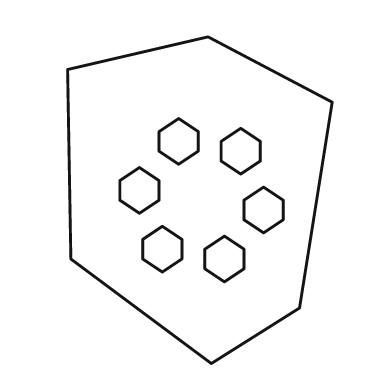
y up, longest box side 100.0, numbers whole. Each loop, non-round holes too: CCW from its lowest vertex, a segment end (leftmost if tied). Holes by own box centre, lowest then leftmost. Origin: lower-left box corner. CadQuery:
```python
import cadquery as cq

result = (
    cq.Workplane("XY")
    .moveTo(44.0, 0.0)
    .lineTo(71.0, 17.0)
    .lineTo(81.0, 80.0)
    .lineTo(43.0, 100.0)
    .lineTo(0.0, 90.0)
    .lineTo(1.0, 32.0)
    .close()
    .moveTo(48.0, 25.0)
    .lineTo(54.0, 29.0)
    .lineTo(54.0, 35.0)
    .lineTo(48.0, 39.0)
    .lineTo(42.0, 35.0)
    .lineTo(42.0, 29.0)
    .close()
    .moveTo(29.0, 28.0)
    .lineTo(35.0, 32.0)
    .lineTo(35.0, 38.0)
    .lineTo(29.0, 42.0)
    .lineTo(23.0, 38.0)
    .lineTo(23.0, 32.0)
    .close()
    .moveTo(60.0, 40.0)
    .lineTo(66.0, 44.0)
    .lineTo(66.0, 50.0)
    .lineTo(60.0, 54.0)
    .lineTo(54.0, 50.0)
    .lineTo(54.0, 44.0)
    .close()
    .moveTo(22.0, 46.0)
    .lineTo(28.0, 50.0)
    .lineTo(28.0, 56.0)
    .lineTo(22.0, 60.0)
    .lineTo(16.0, 56.0)
    .lineTo(16.0, 50.0)
    .close()
    .moveTo(53.0, 58.0)
    .lineTo(59.0, 62.0)
    .lineTo(59.0, 68.0)
    .lineTo(53.0, 72.0)
    .lineTo(47.0, 68.0)
    .lineTo(47.0, 62.0)
    .close()
    .moveTo(34.0, 61.0)
    .lineTo(40.0, 65.0)
    .lineTo(40.0, 71.0)
    .lineTo(34.0, 75.0)
    .lineTo(28.0, 71.0)
    .lineTo(28.0, 65.0)
    .close()
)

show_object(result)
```